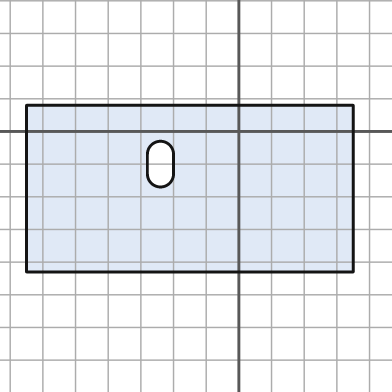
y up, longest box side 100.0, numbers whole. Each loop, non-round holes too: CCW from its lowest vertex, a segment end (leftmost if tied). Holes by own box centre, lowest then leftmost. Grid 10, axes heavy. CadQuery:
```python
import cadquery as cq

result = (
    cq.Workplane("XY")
    .moveTo(-65.0, -43.0)
    .lineTo(35.0, -43.0)
    .lineTo(35.0, 8.0)
    .lineTo(-65.0, 8.0)
    .close()
    .moveTo(-28.0, -13.0)
    .threePointArc((-24.0, -17.0), (-20.0, -13.0))
    .lineTo(-20.0, -7.0)
    .threePointArc((-24.0, -3.0), (-28.0, -7.0))
    .close()
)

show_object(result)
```